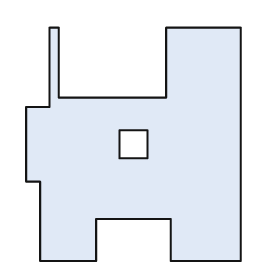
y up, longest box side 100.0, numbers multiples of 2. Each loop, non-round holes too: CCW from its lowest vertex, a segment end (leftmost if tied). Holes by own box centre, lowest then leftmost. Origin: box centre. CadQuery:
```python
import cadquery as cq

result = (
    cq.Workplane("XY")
    .moveTo(-40.0, -50.0)
    .lineTo(-16.0, -50.0)
    .lineTo(-16.0, -32.0)
    .lineTo(16.0, -32.0)
    .lineTo(16.0, -50.0)
    .lineTo(46.0, -50.0)
    .lineTo(46.0, 50.0)
    .lineTo(14.0, 50.0)
    .lineTo(14.0, 20.0)
    .lineTo(-32.0, 20.0)
    .lineTo(-32.0, 50.0)
    .lineTo(-36.0, 50.0)
    .lineTo(-36.0, 16.0)
    .lineTo(-46.0, 16.0)
    .lineTo(-46.0, -16.0)
    .lineTo(-40.0, -16.0)
    .close()
    .moveTo(-6.0, -6.0)
    .lineTo(6.0, -6.0)
    .lineTo(6.0, 6.0)
    .lineTo(-6.0, 6.0)
    .close()
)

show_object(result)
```